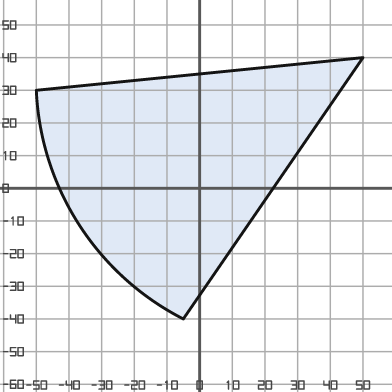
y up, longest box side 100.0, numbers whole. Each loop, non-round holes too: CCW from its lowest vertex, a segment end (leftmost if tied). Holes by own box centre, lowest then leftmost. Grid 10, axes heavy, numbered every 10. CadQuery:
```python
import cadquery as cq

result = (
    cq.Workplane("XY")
    .moveTo(-5.0, -40.0)
    .lineTo(50.0, 40.0)
    .lineTo(-50.0, 30.0)
    .threePointArc((-37.0, -11.0), (-5.0, -40.0))
    .close()
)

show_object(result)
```